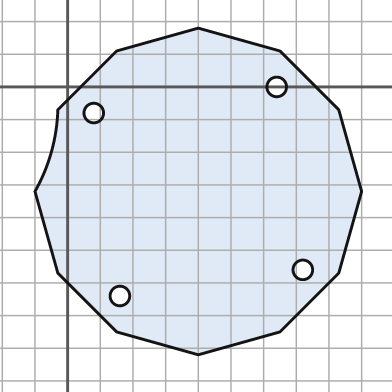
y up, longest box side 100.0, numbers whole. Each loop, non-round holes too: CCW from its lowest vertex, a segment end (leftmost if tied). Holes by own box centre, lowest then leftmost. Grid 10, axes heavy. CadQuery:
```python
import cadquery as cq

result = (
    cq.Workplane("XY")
    .moveTo(40.0, -82.0)
    .lineTo(65.0, -75.0)
    .lineTo(83.0, -57.0)
    .lineTo(90.0, -32.0)
    .lineTo(83.0, -7.0)
    .lineTo(65.0, 11.0)
    .lineTo(40.0, 18.0)
    .lineTo(15.0, 11.0)
    .lineTo(-3.0, -7.0)
    .threePointArc((-5.0, -20.0), (-10.0, -32.0))
    .lineTo(-3.0, -57.0)
    .lineTo(15.0, -75.0)
    .close()
    .moveTo(16.0, -64.0)
    .circle(3.0)
    .moveTo(72.0, -56.0)
    .circle(3.0)
    .moveTo(8.0, -8.0)
    .circle(3.0)
    .moveTo(64.0, 0.0)
    .circle(3.0)
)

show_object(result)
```